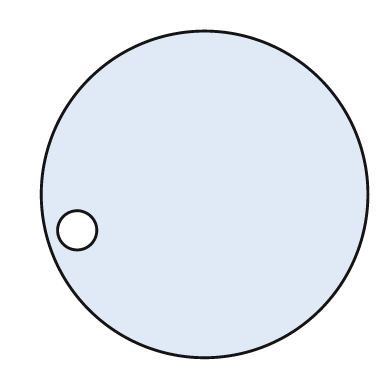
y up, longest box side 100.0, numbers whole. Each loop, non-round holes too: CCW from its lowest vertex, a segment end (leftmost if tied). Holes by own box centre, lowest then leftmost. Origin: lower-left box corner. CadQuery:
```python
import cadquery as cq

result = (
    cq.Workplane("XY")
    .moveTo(50.0, 50.0)
    .circle(50.0)
    .moveTo(11.0, 39.0)
    .circle(6.0)
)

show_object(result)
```